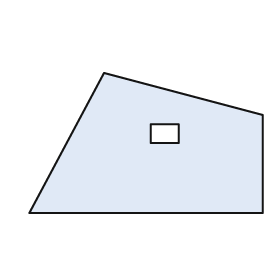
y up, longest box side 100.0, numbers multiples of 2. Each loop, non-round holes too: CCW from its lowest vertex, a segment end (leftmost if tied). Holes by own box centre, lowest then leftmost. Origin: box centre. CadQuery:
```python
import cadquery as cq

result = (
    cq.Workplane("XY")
    .moveTo(-50.0, -30.0)
    .lineTo(50.0, -30.0)
    .lineTo(50.0, 12.0)
    .lineTo(-18.0, 30.0)
    .close()
    .moveTo(2.0, 0.0)
    .lineTo(14.0, 0.0)
    .lineTo(14.0, 8.0)
    .lineTo(2.0, 8.0)
    .close()
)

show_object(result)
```